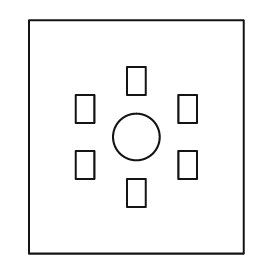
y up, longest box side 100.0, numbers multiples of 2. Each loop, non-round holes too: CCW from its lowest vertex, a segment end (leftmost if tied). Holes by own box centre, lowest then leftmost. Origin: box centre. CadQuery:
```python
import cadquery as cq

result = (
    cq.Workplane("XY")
    .moveTo(-46.0, -50.0)
    .lineTo(46.0, -50.0)
    .lineTo(46.0, 50.0)
    .lineTo(-46.0, 50.0)
    .close()
    .moveTo(-4.0, -30.0)
    .lineTo(4.0, -30.0)
    .lineTo(4.0, -18.0)
    .lineTo(-4.0, -18.0)
    .close()
    .moveTo(-26.0, -18.0)
    .lineTo(-18.0, -18.0)
    .lineTo(-18.0, -6.0)
    .lineTo(-26.0, -6.0)
    .close()
    .moveTo(18.0, -18.0)
    .lineTo(26.0, -18.0)
    .lineTo(26.0, -6.0)
    .lineTo(18.0, -6.0)
    .close()
    .moveTo(0.0, 0.0)
    .circle(10.0)
    .moveTo(-26.0, 6.0)
    .lineTo(-18.0, 6.0)
    .lineTo(-18.0, 18.0)
    .lineTo(-26.0, 18.0)
    .close()
    .moveTo(18.0, 6.0)
    .lineTo(26.0, 6.0)
    .lineTo(26.0, 18.0)
    .lineTo(18.0, 18.0)
    .close()
    .moveTo(-4.0, 18.0)
    .lineTo(4.0, 18.0)
    .lineTo(4.0, 30.0)
    .lineTo(-4.0, 30.0)
    .close()
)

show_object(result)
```